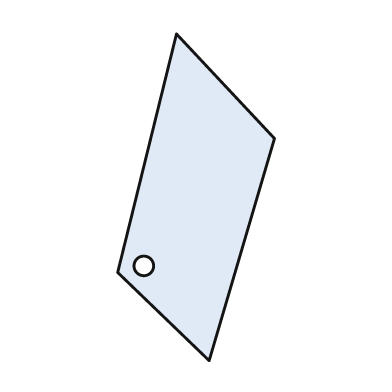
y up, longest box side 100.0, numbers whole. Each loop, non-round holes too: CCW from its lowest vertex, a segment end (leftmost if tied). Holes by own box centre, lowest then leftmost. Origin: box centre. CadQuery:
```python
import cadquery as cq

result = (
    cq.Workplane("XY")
    .moveTo(4.0, -50.0)
    .lineTo(24.0, 18.0)
    .lineTo(-6.0, 50.0)
    .lineTo(-24.0, -23.0)
    .close()
    .moveTo(-16.0, -21.0)
    .circle(3.0)
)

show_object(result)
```